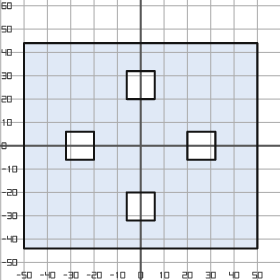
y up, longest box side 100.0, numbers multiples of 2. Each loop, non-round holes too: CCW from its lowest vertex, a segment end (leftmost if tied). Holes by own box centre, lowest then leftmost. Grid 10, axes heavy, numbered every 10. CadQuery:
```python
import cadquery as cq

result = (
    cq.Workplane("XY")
    .moveTo(-50.0, -44.0)
    .lineTo(50.0, -44.0)
    .lineTo(50.0, 44.0)
    .lineTo(-50.0, 44.0)
    .close()
    .moveTo(-6.0, -32.0)
    .lineTo(6.0, -32.0)
    .lineTo(6.0, -20.0)
    .lineTo(-6.0, -20.0)
    .close()
    .moveTo(-32.0, -6.0)
    .lineTo(-20.0, -6.0)
    .lineTo(-20.0, 6.0)
    .lineTo(-32.0, 6.0)
    .close()
    .moveTo(20.0, -6.0)
    .lineTo(32.0, -6.0)
    .lineTo(32.0, 6.0)
    .lineTo(20.0, 6.0)
    .close()
    .moveTo(-6.0, 20.0)
    .lineTo(6.0, 20.0)
    .lineTo(6.0, 32.0)
    .lineTo(-6.0, 32.0)
    .close()
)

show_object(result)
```